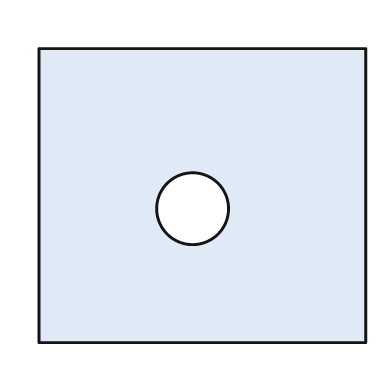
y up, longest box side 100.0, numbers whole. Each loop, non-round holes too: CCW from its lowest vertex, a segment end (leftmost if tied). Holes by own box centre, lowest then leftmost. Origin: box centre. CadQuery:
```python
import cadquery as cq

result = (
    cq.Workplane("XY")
    .moveTo(-50.0, -45.0)
    .lineTo(50.0, -45.0)
    .lineTo(50.0, 45.0)
    .lineTo(-50.0, 45.0)
    .close()
    .moveTo(-3.0, -4.0)
    .circle(11.0)
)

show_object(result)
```